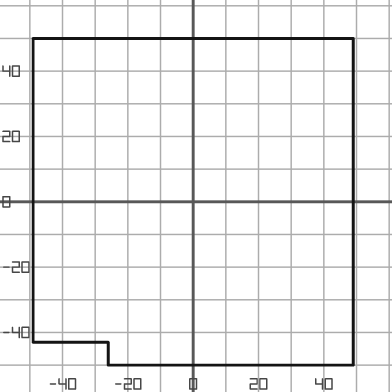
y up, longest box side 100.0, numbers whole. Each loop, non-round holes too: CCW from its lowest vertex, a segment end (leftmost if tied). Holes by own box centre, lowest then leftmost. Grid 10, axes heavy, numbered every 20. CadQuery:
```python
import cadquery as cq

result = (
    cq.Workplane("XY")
    .moveTo(-26.0, -50.0)
    .lineTo(49.0, -50.0)
    .lineTo(49.0, 50.0)
    .lineTo(-49.0, 50.0)
    .lineTo(-49.0, -43.0)
    .lineTo(-26.0, -43.0)
    .close()
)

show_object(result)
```